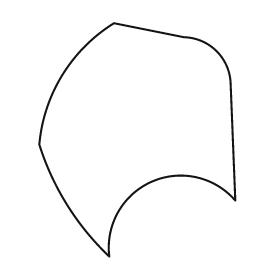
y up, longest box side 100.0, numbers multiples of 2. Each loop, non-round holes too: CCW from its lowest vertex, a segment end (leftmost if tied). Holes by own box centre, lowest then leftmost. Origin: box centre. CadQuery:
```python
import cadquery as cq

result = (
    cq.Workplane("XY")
    .moveTo(-12.0, -50.0)
    .threePointArc((6.0, -18.0), (42.0, -26.0))
    .lineTo(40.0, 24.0)
    .threePointArc((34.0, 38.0), (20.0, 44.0))
    .lineTo(-10.0, 50.0)
    .threePointArc((-32.0, 28.0), (-42.0, -2.0))
    .threePointArc((-30.0, -28.0), (-12.0, -50.0))
    .close()
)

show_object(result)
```